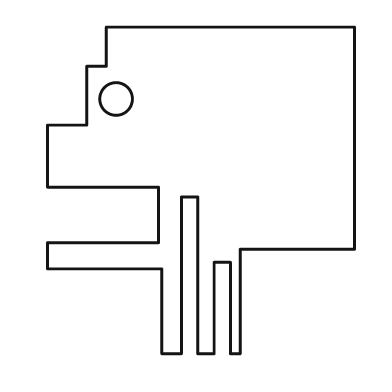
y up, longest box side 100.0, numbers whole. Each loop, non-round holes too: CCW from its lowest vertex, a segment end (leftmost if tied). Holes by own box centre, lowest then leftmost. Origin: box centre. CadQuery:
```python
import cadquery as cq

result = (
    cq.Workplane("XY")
    .moveTo(-12.0, -50.0)
    .lineTo(-6.0, -50.0)
    .lineTo(-6.0, -2.0)
    .lineTo(-1.0, -2.0)
    .lineTo(-1.0, -50.0)
    .lineTo(4.0, -50.0)
    .lineTo(4.0, -22.0)
    .lineTo(9.0, -22.0)
    .lineTo(9.0, -50.0)
    .lineTo(12.0, -50.0)
    .lineTo(12.0, -18.0)
    .lineTo(47.0, -18.0)
    .lineTo(47.0, 50.0)
    .lineTo(-29.0, 50.0)
    .lineTo(-29.0, 38.0)
    .lineTo(-35.0, 38.0)
    .lineTo(-35.0, 20.0)
    .lineTo(-47.0, 20.0)
    .lineTo(-47.0, 1.0)
    .lineTo(-13.0, 1.0)
    .lineTo(-13.0, -16.0)
    .lineTo(-47.0, -16.0)
    .lineTo(-47.0, -24.0)
    .lineTo(-12.0, -24.0)
    .close()
    .moveTo(-26.0, 28.0)
    .circle(5.0)
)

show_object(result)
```